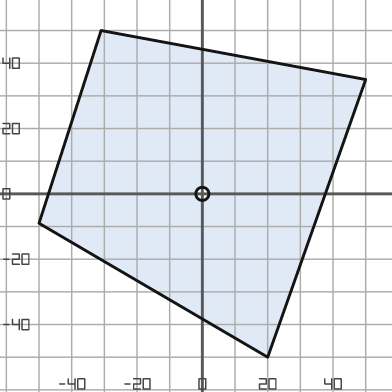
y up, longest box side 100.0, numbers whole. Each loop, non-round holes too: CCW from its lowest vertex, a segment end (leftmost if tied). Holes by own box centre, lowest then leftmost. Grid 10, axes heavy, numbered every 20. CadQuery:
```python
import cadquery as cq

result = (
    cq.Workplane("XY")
    .moveTo(20.0, -50.0)
    .lineTo(50.0, 35.0)
    .lineTo(-31.0, 50.0)
    .lineTo(-50.0, -9.0)
    .close()
    .moveTo(0.0, 0.0)
    .circle(2.0)
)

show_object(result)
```